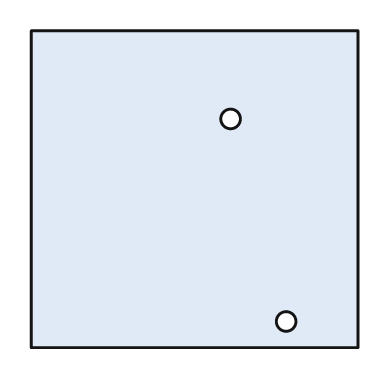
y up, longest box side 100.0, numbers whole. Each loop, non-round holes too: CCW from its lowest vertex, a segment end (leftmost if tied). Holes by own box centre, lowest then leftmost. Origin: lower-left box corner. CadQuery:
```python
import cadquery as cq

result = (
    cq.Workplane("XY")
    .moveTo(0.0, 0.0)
    .lineTo(100.0, 0.0)
    .lineTo(100.0, 97.0)
    .lineTo(0.0, 97.0)
    .close()
    .moveTo(78.0, 8.0)
    .circle(3.0)
    .moveTo(61.0, 70.0)
    .circle(3.0)
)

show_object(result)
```